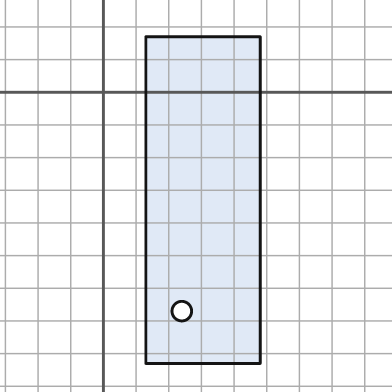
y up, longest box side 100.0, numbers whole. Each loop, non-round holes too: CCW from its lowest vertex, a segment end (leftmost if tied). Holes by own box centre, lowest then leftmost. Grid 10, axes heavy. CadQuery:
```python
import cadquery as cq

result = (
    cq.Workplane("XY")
    .moveTo(13.0, -83.0)
    .lineTo(48.0, -83.0)
    .lineTo(48.0, 17.0)
    .lineTo(13.0, 17.0)
    .close()
    .moveTo(24.0, -67.0)
    .circle(3.0)
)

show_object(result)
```